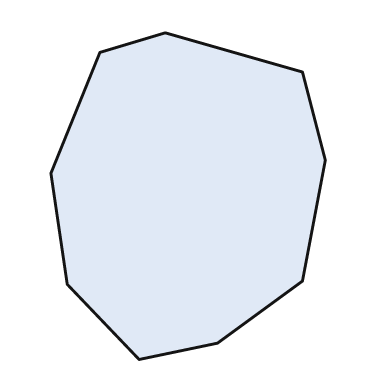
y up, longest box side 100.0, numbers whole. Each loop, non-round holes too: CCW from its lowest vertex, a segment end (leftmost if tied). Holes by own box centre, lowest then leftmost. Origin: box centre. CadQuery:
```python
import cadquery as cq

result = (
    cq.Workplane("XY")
    .moveTo(-15.0, -50.0)
    .lineTo(9.0, -45.0)
    .lineTo(35.0, -26.0)
    .lineTo(42.0, 11.0)
    .lineTo(35.0, 38.0)
    .lineTo(-7.0, 50.0)
    .lineTo(-27.0, 44.0)
    .lineTo(-42.0, 7.0)
    .lineTo(-37.0, -27.0)
    .close()
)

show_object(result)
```